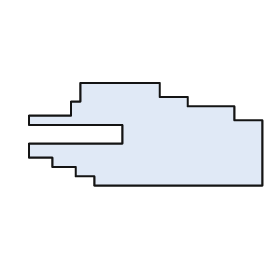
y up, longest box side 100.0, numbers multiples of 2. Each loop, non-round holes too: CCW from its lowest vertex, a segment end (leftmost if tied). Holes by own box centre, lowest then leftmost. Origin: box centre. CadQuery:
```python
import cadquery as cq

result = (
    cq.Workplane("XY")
    .moveTo(-22.0, -22.0)
    .lineTo(50.0, -22.0)
    .lineTo(50.0, 6.0)
    .lineTo(38.0, 6.0)
    .lineTo(38.0, 12.0)
    .lineTo(18.0, 12.0)
    .lineTo(18.0, 16.0)
    .lineTo(6.0, 16.0)
    .lineTo(6.0, 22.0)
    .lineTo(-28.0, 22.0)
    .lineTo(-28.0, 14.0)
    .lineTo(-32.0, 14.0)
    .lineTo(-32.0, 8.0)
    .lineTo(-50.0, 8.0)
    .lineTo(-50.0, 4.0)
    .lineTo(-10.0, 4.0)
    .lineTo(-10.0, -4.0)
    .lineTo(-50.0, -4.0)
    .lineTo(-50.0, -10.0)
    .lineTo(-40.0, -10.0)
    .lineTo(-40.0, -14.0)
    .lineTo(-30.0, -14.0)
    .lineTo(-30.0, -18.0)
    .lineTo(-22.0, -18.0)
    .close()
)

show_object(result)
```